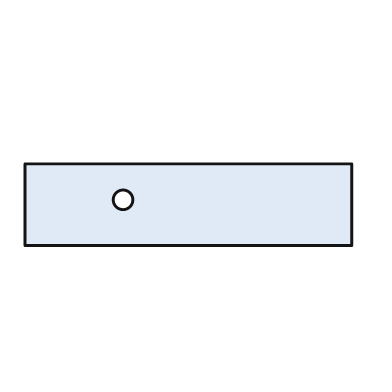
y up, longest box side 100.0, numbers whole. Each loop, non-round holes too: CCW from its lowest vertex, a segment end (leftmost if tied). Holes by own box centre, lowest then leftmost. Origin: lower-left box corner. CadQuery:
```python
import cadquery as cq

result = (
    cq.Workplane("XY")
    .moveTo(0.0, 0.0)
    .lineTo(100.0, 0.0)
    .lineTo(100.0, 25.0)
    .lineTo(0.0, 25.0)
    .close()
    .moveTo(30.0, 14.0)
    .circle(3.0)
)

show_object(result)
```